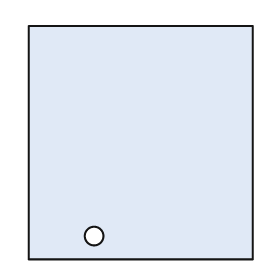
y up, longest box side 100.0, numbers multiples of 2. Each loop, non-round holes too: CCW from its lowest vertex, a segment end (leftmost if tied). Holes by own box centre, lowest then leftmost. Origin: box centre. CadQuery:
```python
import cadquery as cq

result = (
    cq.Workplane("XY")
    .moveTo(-48.0, -50.0)
    .lineTo(48.0, -50.0)
    .lineTo(48.0, 50.0)
    .lineTo(-48.0, 50.0)
    .close()
    .moveTo(-20.0, -40.0)
    .circle(4.0)
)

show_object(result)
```